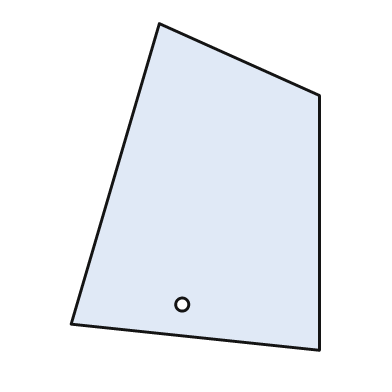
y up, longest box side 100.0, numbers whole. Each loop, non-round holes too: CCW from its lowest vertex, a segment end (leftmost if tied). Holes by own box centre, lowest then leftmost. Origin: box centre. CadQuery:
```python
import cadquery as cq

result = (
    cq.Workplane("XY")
    .moveTo(38.0, -50.0)
    .lineTo(38.0, 28.0)
    .lineTo(-11.0, 50.0)
    .lineTo(-38.0, -42.0)
    .close()
    .moveTo(-4.0, -36.0)
    .circle(2.0)
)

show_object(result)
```